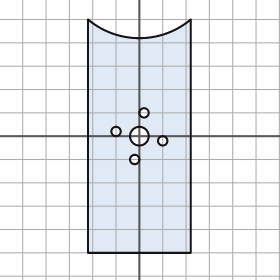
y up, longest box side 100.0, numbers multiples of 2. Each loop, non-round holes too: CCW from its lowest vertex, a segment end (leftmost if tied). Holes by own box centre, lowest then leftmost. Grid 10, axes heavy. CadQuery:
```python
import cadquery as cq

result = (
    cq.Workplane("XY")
    .moveTo(-22.0, -50.0)
    .lineTo(22.0, -50.0)
    .lineTo(22.0, 50.0)
    .threePointArc((0.0, 42.0), (-22.0, 50.0))
    .close()
    .moveTo(-2.0, -10.0)
    .circle(2.0)
    .moveTo(10.0, -2.0)
    .circle(2.0)
    .moveTo(0.0, 0.0)
    .circle(4.0)
    .moveTo(-10.0, 2.0)
    .circle(2.0)
    .moveTo(2.0, 10.0)
    .circle(2.0)
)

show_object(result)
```